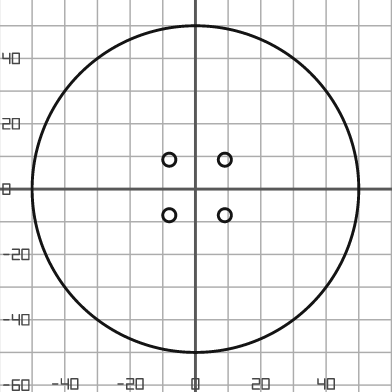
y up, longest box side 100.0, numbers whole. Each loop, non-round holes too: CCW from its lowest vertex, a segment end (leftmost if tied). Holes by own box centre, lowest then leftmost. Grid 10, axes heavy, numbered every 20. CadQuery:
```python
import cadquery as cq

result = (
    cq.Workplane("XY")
    .moveTo(0.0, 0.0)
    .circle(50.0)
    .moveTo(-8.0, -8.0)
    .circle(2.0)
    .moveTo(9.0, -8.0)
    .circle(2.0)
    .moveTo(-8.0, 9.0)
    .circle(2.0)
    .moveTo(9.0, 9.0)
    .circle(2.0)
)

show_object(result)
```